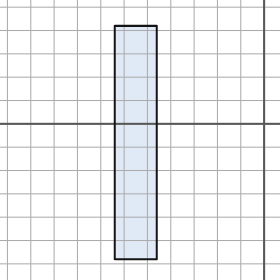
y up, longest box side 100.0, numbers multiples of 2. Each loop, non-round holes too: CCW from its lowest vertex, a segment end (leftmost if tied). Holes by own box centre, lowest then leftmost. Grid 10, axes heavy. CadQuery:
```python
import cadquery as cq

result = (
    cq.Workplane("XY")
    .moveTo(-64.0, -58.0)
    .lineTo(-46.0, -58.0)
    .lineTo(-46.0, 42.0)
    .lineTo(-64.0, 42.0)
    .close()
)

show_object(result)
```